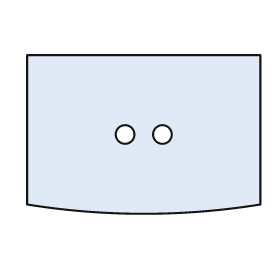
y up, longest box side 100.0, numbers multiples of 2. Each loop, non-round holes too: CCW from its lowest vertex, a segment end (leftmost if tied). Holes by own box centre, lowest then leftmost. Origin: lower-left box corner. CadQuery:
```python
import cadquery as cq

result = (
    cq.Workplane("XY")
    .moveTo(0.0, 4.0)
    .threePointArc((50.0, 0.0), (100.0, 4.0))
    .lineTo(100.0, 68.0)
    .lineTo(0.0, 68.0)
    .close()
    .moveTo(42.0, 34.0)
    .circle(4.0)
    .moveTo(58.0, 34.0)
    .circle(4.0)
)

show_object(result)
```